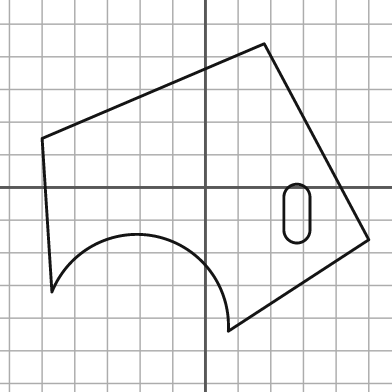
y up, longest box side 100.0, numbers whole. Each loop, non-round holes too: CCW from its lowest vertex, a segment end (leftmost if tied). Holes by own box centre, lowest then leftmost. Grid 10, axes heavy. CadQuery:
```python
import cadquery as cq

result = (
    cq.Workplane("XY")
    .moveTo(7.0, -44.0)
    .lineTo(50.0, -16.0)
    .lineTo(18.0, 44.0)
    .lineTo(-50.0, 15.0)
    .lineTo(-47.0, -32.0)
    .threePointArc((-15.0, -15.0), (7.0, -44.0))
    .close()
    .moveTo(24.0, -13.0)
    .threePointArc((28.0, -17.0), (32.0, -13.0))
    .lineTo(32.0, -3.0)
    .threePointArc((28.0, 1.0), (24.0, -3.0))
    .close()
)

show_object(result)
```